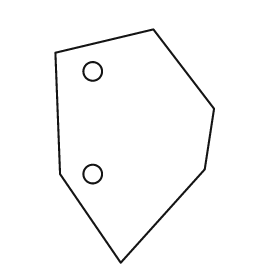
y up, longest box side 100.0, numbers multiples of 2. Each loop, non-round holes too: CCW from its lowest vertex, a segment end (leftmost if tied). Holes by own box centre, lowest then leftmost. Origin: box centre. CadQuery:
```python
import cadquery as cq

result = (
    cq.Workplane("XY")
    .moveTo(-6.0, -50.0)
    .lineTo(30.0, -10.0)
    .lineTo(34.0, 16.0)
    .lineTo(8.0, 50.0)
    .lineTo(-34.0, 40.0)
    .lineTo(-32.0, -12.0)
    .close()
    .moveTo(-18.0, -12.0)
    .circle(4.0)
    .moveTo(-18.0, 32.0)
    .circle(4.0)
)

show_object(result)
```